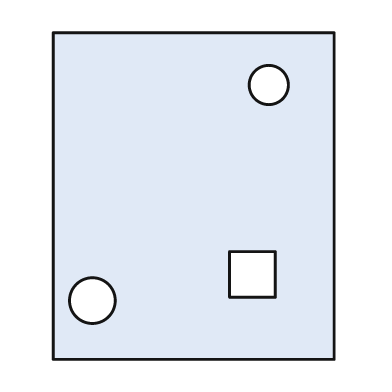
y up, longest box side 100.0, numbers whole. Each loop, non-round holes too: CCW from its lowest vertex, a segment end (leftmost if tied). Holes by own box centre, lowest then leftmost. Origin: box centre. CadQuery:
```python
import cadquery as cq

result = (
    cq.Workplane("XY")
    .moveTo(-43.0, -50.0)
    .lineTo(43.0, -50.0)
    .lineTo(43.0, 50.0)
    .lineTo(-43.0, 50.0)
    .close()
    .moveTo(-31.0, -32.0)
    .circle(7.0)
    .moveTo(11.0, -31.0)
    .lineTo(25.0, -31.0)
    .lineTo(25.0, -17.0)
    .lineTo(11.0, -17.0)
    .close()
    .moveTo(23.0, 34.0)
    .circle(6.0)
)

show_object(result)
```